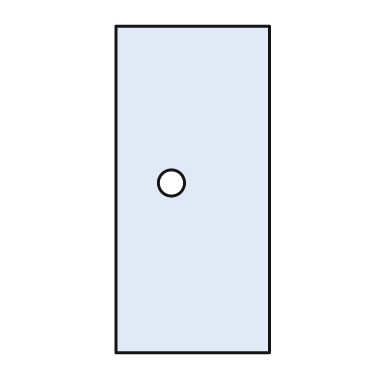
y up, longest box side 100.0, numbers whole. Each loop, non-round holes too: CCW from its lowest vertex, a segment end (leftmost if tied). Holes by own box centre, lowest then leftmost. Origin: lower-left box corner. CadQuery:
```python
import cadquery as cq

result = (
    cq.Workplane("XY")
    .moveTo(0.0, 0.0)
    .lineTo(47.0, 0.0)
    .lineTo(47.0, 100.0)
    .lineTo(0.0, 100.0)
    .close()
    .moveTo(17.0, 52.0)
    .circle(4.0)
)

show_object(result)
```